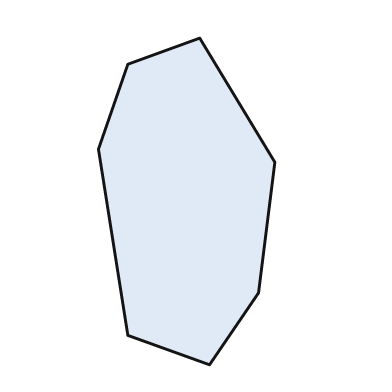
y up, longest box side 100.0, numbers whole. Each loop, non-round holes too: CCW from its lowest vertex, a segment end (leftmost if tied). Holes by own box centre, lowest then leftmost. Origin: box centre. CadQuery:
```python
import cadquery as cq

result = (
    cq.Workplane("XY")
    .moveTo(7.0, -50.0)
    .lineTo(22.0, -28.0)
    .lineTo(27.0, 12.0)
    .lineTo(4.0, 50.0)
    .lineTo(-18.0, 42.0)
    .lineTo(-27.0, 16.0)
    .lineTo(-18.0, -41.0)
    .close()
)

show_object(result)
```